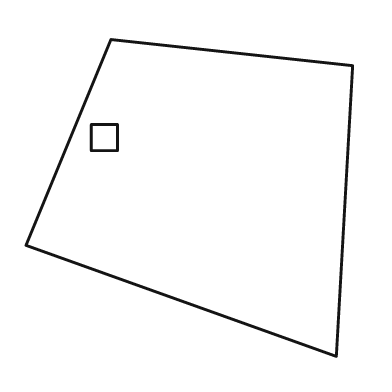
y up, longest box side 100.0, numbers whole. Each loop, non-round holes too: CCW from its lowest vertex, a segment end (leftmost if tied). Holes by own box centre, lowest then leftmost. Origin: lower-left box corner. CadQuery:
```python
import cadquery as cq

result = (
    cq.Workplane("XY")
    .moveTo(95.0, 0.0)
    .lineTo(100.0, 89.0)
    .lineTo(26.0, 97.0)
    .lineTo(0.0, 34.0)
    .close()
    .moveTo(20.0, 63.0)
    .lineTo(28.0, 63.0)
    .lineTo(28.0, 71.0)
    .lineTo(20.0, 71.0)
    .close()
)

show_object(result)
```